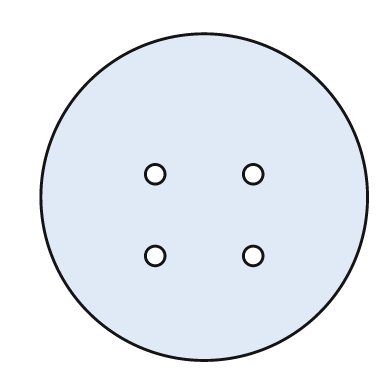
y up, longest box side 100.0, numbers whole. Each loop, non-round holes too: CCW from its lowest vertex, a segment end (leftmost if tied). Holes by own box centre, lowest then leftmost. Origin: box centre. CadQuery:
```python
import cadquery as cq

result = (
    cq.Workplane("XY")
    .moveTo(0.0, 0.0)
    .circle(50.0)
    .moveTo(-15.0, -18.0)
    .circle(3.0)
    .moveTo(15.0, -18.0)
    .circle(3.0)
    .moveTo(-15.0, 7.0)
    .circle(3.0)
    .moveTo(15.0, 7.0)
    .circle(3.0)
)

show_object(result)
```